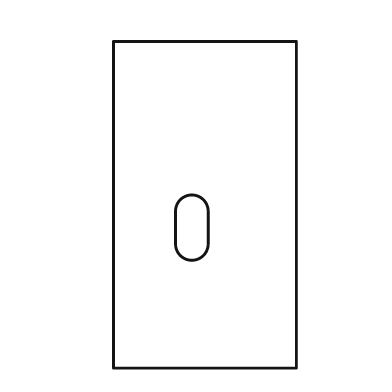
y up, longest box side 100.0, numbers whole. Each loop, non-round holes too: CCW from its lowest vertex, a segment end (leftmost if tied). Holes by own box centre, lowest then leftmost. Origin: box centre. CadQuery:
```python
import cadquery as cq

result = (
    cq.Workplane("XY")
    .moveTo(-28.0, -50.0)
    .lineTo(28.0, -50.0)
    .lineTo(28.0, 50.0)
    .lineTo(-28.0, 50.0)
    .close()
    .moveTo(-9.0, -12.0)
    .threePointArc((-4.0, -17.0), (1.0, -12.0))
    .lineTo(1.0, -2.0)
    .threePointArc((-4.0, 3.0), (-9.0, -2.0))
    .close()
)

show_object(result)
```